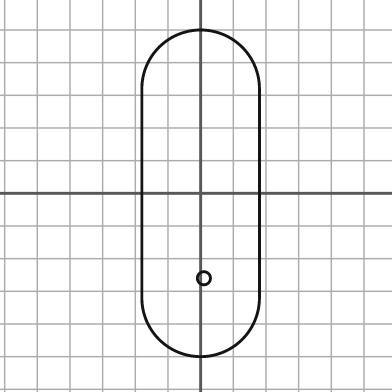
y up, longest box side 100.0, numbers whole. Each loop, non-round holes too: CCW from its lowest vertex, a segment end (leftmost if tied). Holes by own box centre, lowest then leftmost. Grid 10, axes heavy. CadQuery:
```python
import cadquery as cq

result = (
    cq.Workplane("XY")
    .moveTo(-18.0, -32.0)
    .threePointArc((0.0, -50.0), (18.0, -32.0))
    .lineTo(18.0, 32.0)
    .threePointArc((0.0, 50.0), (-18.0, 32.0))
    .close()
    .moveTo(1.0, -26.0)
    .circle(2.0)
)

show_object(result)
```